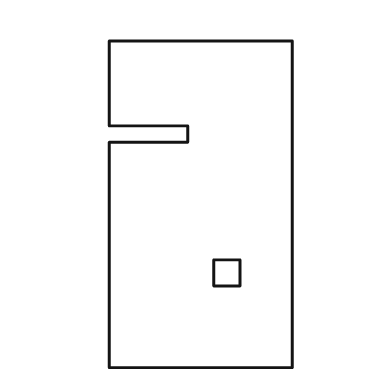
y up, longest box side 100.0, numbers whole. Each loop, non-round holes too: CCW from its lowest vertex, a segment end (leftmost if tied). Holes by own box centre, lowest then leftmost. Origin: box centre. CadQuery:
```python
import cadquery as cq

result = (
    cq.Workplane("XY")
    .moveTo(-28.0, -50.0)
    .lineTo(28.0, -50.0)
    .lineTo(28.0, 50.0)
    .lineTo(-28.0, 50.0)
    .lineTo(-28.0, 24.0)
    .lineTo(-4.0, 24.0)
    .lineTo(-4.0, 19.0)
    .lineTo(-28.0, 19.0)
    .close()
    .moveTo(4.0, -25.0)
    .lineTo(12.0, -25.0)
    .lineTo(12.0, -17.0)
    .lineTo(4.0, -17.0)
    .close()
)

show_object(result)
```